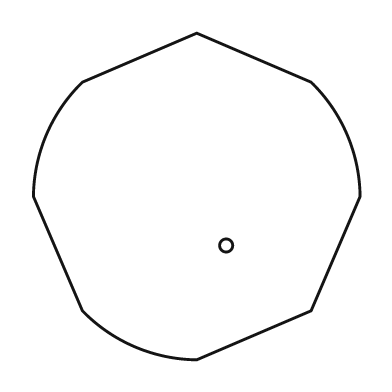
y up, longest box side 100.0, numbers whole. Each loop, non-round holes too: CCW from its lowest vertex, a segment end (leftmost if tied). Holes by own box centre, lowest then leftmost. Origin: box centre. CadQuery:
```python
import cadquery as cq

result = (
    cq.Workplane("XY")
    .moveTo(0.0, -50.0)
    .lineTo(35.0, -35.0)
    .lineTo(50.0, 0.0)
    .threePointArc((46.0, 19.0), (35.0, 35.0))
    .lineTo(0.0, 50.0)
    .lineTo(-35.0, 35.0)
    .threePointArc((-46.0, 19.0), (-50.0, 0.0))
    .lineTo(-35.0, -35.0)
    .threePointArc((-19.0, -46.0), (0.0, -50.0))
    .close()
    .moveTo(9.0, -15.0)
    .circle(2.0)
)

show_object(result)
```